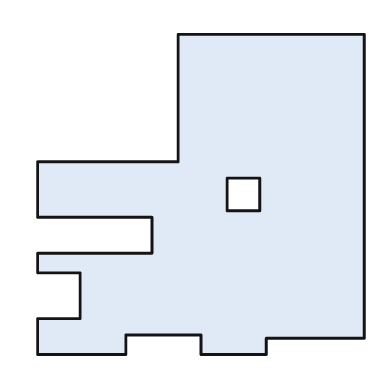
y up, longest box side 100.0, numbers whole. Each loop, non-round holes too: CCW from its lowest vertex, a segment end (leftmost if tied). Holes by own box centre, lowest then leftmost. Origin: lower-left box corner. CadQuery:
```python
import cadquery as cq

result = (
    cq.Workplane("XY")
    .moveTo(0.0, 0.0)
    .lineTo(27.0, 0.0)
    .lineTo(27.0, 6.0)
    .lineTo(50.0, 6.0)
    .lineTo(50.0, 0.0)
    .lineTo(70.0, 0.0)
    .lineTo(70.0, 5.0)
    .lineTo(100.0, 5.0)
    .lineTo(100.0, 98.0)
    .lineTo(43.0, 98.0)
    .lineTo(43.0, 59.0)
    .lineTo(0.0, 59.0)
    .lineTo(0.0, 42.0)
    .lineTo(35.0, 42.0)
    .lineTo(35.0, 31.0)
    .lineTo(0.0, 31.0)
    .lineTo(0.0, 25.0)
    .lineTo(13.0, 25.0)
    .lineTo(13.0, 11.0)
    .lineTo(0.0, 11.0)
    .close()
    .moveTo(58.0, 44.0)
    .lineTo(68.0, 44.0)
    .lineTo(68.0, 54.0)
    .lineTo(58.0, 54.0)
    .close()
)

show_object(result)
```